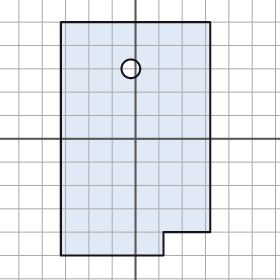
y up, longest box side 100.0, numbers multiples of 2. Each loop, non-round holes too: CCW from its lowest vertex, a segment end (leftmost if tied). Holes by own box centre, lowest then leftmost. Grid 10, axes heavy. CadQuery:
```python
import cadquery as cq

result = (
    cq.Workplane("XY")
    .moveTo(-32.0, -50.0)
    .lineTo(12.0, -50.0)
    .lineTo(12.0, -40.0)
    .lineTo(32.0, -40.0)
    .lineTo(32.0, 50.0)
    .lineTo(-32.0, 50.0)
    .close()
    .moveTo(-2.0, 30.0)
    .circle(4.0)
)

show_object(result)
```